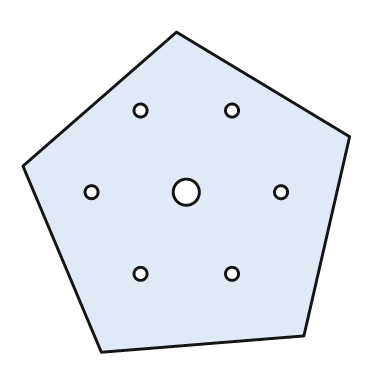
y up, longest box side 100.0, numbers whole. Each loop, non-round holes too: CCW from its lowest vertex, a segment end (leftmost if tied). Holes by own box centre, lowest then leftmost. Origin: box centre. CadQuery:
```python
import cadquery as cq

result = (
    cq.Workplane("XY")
    .moveTo(-26.0, -49.0)
    .lineTo(36.0, -44.0)
    .lineTo(50.0, 17.0)
    .lineTo(-3.0, 49.0)
    .lineTo(-50.0, 8.0)
    .close()
    .moveTo(-14.0, -25.0)
    .circle(2.0)
    .moveTo(14.0, -25.0)
    .circle(2.0)
    .moveTo(-29.0, 0.0)
    .circle(2.0)
    .moveTo(0.0, 0.0)
    .circle(4.0)
    .moveTo(29.0, 0.0)
    .circle(2.0)
    .moveTo(-14.0, 25.0)
    .circle(2.0)
    .moveTo(14.0, 25.0)
    .circle(2.0)
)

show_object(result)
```